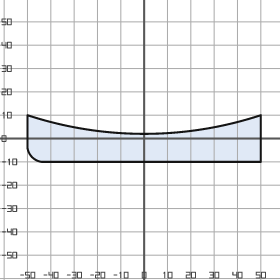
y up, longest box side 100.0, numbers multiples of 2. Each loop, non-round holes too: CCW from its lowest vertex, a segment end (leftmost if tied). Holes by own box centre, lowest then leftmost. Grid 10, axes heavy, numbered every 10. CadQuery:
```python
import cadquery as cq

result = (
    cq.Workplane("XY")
    .moveTo(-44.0, -10.0)
    .lineTo(50.0, -10.0)
    .lineTo(50.0, 10.0)
    .threePointArc((0.0, 2.0), (-50.0, 10.0))
    .lineTo(-50.0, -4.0)
    .threePointArc((-48.0, -8.0), (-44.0, -10.0))
    .close()
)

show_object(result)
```